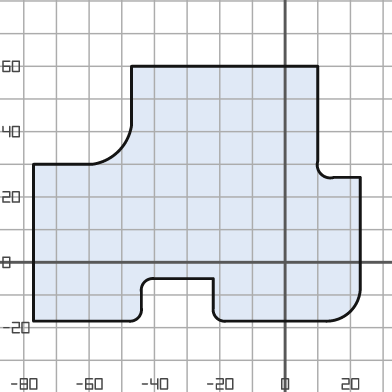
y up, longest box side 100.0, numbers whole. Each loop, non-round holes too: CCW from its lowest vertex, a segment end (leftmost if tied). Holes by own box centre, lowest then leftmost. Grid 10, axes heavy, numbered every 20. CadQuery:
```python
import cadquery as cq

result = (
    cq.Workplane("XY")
    .moveTo(-77.0, -18.0)
    .lineTo(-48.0, -18.0)
    .threePointArc((-45.0, -17.0), (-44.0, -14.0))
    .lineTo(-44.0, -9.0)
    .threePointArc((-43.0, -6.0), (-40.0, -5.0))
    .lineTo(-22.0, -5.0)
    .lineTo(-22.0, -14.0)
    .threePointArc((-21.0, -17.0), (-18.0, -18.0))
    .lineTo(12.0, -18.0)
    .threePointArc((20.0, -15.0), (23.0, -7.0))
    .lineTo(23.0, 26.0)
    .lineTo(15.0, 26.0)
    .threePointArc((11.0, 27.0), (10.0, 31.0))
    .lineTo(10.0, 60.0)
    .lineTo(-47.0, 60.0)
    .lineTo(-47.0, 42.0)
    .threePointArc((-51.0, 34.0), (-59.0, 30.0))
    .lineTo(-77.0, 30.0)
    .close()
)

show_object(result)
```